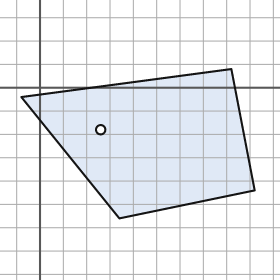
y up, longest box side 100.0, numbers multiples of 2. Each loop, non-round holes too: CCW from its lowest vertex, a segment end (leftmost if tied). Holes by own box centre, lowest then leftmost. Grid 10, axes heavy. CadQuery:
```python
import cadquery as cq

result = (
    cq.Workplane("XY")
    .moveTo(34.0, -56.0)
    .lineTo(92.0, -44.0)
    .lineTo(82.0, 8.0)
    .lineTo(-8.0, -4.0)
    .close()
    .moveTo(26.0, -18.0)
    .circle(2.0)
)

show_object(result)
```